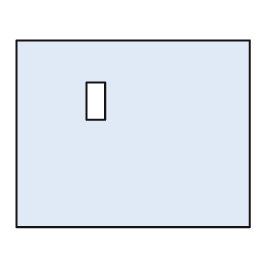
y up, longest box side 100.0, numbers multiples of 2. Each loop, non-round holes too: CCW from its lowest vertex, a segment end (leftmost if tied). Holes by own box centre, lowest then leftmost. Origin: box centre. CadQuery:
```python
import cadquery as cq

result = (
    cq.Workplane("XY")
    .moveTo(-50.0, -40.0)
    .lineTo(50.0, -40.0)
    .lineTo(50.0, 40.0)
    .lineTo(-50.0, 40.0)
    .close()
    .moveTo(-20.0, 6.0)
    .lineTo(-12.0, 6.0)
    .lineTo(-12.0, 22.0)
    .lineTo(-20.0, 22.0)
    .close()
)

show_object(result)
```